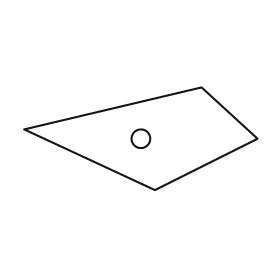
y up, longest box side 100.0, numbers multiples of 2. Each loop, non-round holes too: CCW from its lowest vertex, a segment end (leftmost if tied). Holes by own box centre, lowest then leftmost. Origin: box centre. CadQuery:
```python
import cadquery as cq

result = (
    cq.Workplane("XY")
    .moveTo(6.0, -22.0)
    .lineTo(50.0, 0.0)
    .lineTo(26.0, 22.0)
    .lineTo(-50.0, 4.0)
    .close()
    .moveTo(0.0, 0.0)
    .circle(4.0)
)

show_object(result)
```